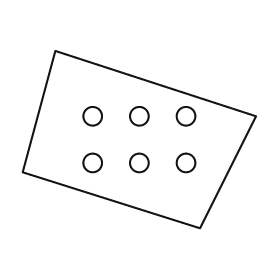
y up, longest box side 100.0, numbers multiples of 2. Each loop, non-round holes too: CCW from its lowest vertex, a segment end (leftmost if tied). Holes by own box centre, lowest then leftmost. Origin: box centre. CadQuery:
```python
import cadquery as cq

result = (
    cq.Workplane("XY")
    .moveTo(26.0, -38.0)
    .lineTo(50.0, 10.0)
    .lineTo(-36.0, 38.0)
    .lineTo(-50.0, -14.0)
    .close()
    .moveTo(-20.0, -10.0)
    .circle(4.0)
    .moveTo(0.0, -10.0)
    .circle(4.0)
    .moveTo(20.0, -10.0)
    .circle(4.0)
    .moveTo(-20.0, 10.0)
    .circle(4.0)
    .moveTo(0.0, 10.0)
    .circle(4.0)
    .moveTo(20.0, 10.0)
    .circle(4.0)
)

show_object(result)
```